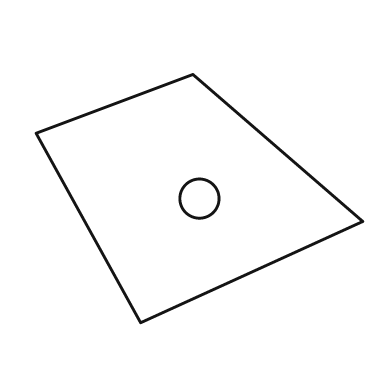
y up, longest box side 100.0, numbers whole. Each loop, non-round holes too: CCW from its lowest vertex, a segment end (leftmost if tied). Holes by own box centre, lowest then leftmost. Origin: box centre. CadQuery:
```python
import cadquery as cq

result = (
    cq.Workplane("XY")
    .moveTo(-18.0, -38.0)
    .lineTo(50.0, -7.0)
    .lineTo(-2.0, 38.0)
    .lineTo(-50.0, 20.0)
    .close()
    .moveTo(0.0, 0.0)
    .circle(6.0)
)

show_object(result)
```